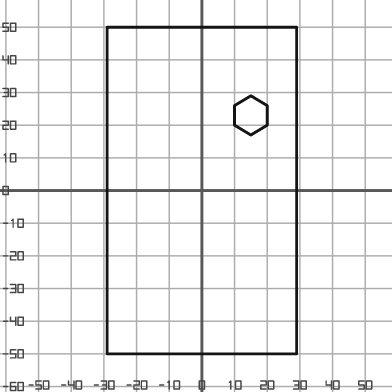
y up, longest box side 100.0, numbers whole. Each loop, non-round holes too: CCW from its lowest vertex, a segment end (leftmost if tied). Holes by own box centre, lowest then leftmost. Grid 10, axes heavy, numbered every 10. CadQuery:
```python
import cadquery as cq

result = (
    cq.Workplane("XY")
    .moveTo(-29.0, -50.0)
    .lineTo(29.0, -50.0)
    .lineTo(29.0, 50.0)
    .lineTo(-29.0, 50.0)
    .close()
    .moveTo(15.0, 17.0)
    .lineTo(20.0, 20.0)
    .lineTo(20.0, 26.0)
    .lineTo(15.0, 29.0)
    .lineTo(10.0, 26.0)
    .lineTo(10.0, 20.0)
    .close()
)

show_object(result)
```